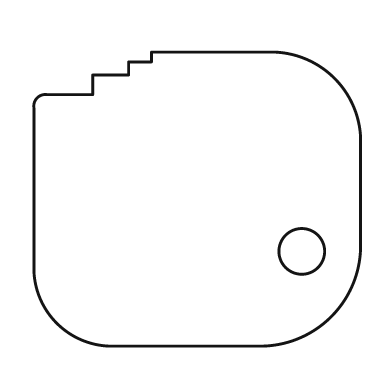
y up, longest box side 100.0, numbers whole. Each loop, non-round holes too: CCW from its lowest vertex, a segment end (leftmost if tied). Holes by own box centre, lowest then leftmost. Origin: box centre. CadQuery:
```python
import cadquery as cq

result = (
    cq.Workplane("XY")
    .moveTo(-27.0, -45.0)
    .lineTo(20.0, -45.0)
    .threePointArc((41.0, -36.0), (50.0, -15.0))
    .lineTo(50.0, 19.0)
    .threePointArc((42.0, 37.0), (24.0, 45.0))
    .lineTo(-14.0, 45.0)
    .lineTo(-14.0, 42.0)
    .lineTo(-21.0, 42.0)
    .lineTo(-21.0, 38.0)
    .lineTo(-32.0, 38.0)
    .lineTo(-32.0, 32.0)
    .lineTo(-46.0, 32.0)
    .threePointArc((-49.0, 31.0), (-50.0, 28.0))
    .lineTo(-50.0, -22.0)
    .threePointArc((-43.0, -38.0), (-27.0, -45.0))
    .close()
    .moveTo(32.0, -16.0)
    .circle(7.0)
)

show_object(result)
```